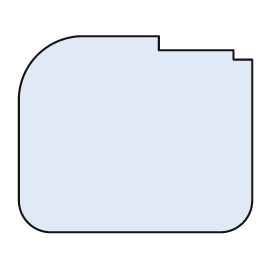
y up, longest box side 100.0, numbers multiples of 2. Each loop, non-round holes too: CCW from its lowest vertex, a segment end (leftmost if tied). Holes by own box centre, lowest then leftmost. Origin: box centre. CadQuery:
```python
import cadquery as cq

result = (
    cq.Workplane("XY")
    .moveTo(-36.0, -42.0)
    .lineTo(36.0, -42.0)
    .threePointArc((46.0, -38.0), (50.0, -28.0))
    .lineTo(50.0, 32.0)
    .lineTo(42.0, 32.0)
    .lineTo(42.0, 36.0)
    .lineTo(10.0, 36.0)
    .lineTo(10.0, 42.0)
    .lineTo(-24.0, 42.0)
    .threePointArc((-42.0, 34.0), (-50.0, 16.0))
    .lineTo(-50.0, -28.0)
    .threePointArc((-46.0, -38.0), (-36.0, -42.0))
    .close()
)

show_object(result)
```